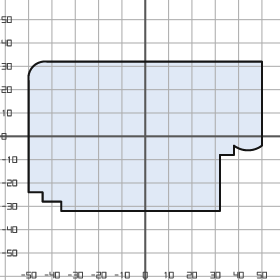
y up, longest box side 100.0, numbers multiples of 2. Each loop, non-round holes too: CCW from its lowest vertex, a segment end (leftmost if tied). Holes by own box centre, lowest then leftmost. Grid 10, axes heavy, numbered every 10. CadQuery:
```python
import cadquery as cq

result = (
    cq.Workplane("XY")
    .moveTo(-36.0, -32.0)
    .lineTo(32.0, -32.0)
    .lineTo(32.0, -8.0)
    .lineTo(38.0, -8.0)
    .lineTo(38.0, -4.0)
    .threePointArc((44.0, -6.0), (50.0, -4.0))
    .lineTo(50.0, 32.0)
    .lineTo(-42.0, 32.0)
    .threePointArc((-48.0, 30.0), (-50.0, 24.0))
    .lineTo(-50.0, -24.0)
    .lineTo(-44.0, -24.0)
    .lineTo(-44.0, -28.0)
    .lineTo(-36.0, -28.0)
    .close()
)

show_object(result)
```